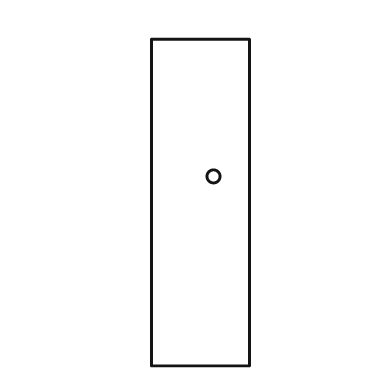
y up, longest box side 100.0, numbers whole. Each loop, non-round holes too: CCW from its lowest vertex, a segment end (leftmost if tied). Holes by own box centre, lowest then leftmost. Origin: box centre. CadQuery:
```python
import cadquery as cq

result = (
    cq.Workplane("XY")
    .moveTo(-15.0, -50.0)
    .lineTo(15.0, -50.0)
    .lineTo(15.0, 50.0)
    .lineTo(-15.0, 50.0)
    .close()
    .moveTo(4.0, 8.0)
    .circle(2.0)
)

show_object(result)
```